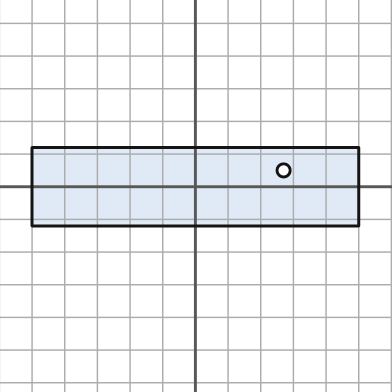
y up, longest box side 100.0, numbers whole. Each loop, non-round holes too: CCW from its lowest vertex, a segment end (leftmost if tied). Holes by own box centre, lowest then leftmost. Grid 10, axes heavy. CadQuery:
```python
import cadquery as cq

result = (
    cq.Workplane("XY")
    .moveTo(-50.0, -12.0)
    .lineTo(50.0, -12.0)
    .lineTo(50.0, 12.0)
    .lineTo(-50.0, 12.0)
    .close()
    .moveTo(27.0, 5.0)
    .circle(2.0)
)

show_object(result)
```